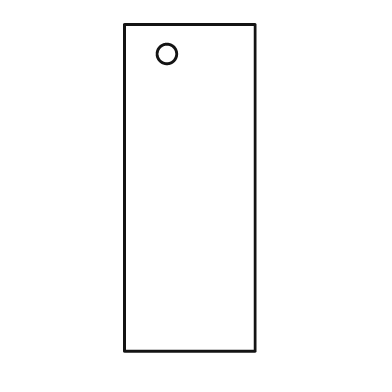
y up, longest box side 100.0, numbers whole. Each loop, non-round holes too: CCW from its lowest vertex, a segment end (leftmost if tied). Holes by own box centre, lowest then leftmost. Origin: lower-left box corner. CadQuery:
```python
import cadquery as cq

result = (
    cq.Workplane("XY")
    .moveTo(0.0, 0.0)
    .lineTo(40.0, 0.0)
    .lineTo(40.0, 100.0)
    .lineTo(0.0, 100.0)
    .close()
    .moveTo(13.0, 91.0)
    .circle(3.0)
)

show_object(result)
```